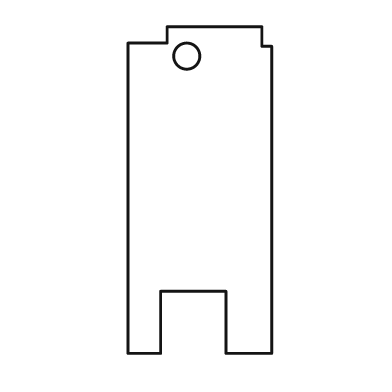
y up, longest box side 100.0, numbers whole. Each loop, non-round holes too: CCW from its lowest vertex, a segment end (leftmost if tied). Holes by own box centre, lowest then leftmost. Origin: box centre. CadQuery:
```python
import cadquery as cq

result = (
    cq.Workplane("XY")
    .moveTo(-22.0, -50.0)
    .lineTo(-12.0, -50.0)
    .lineTo(-12.0, -31.0)
    .lineTo(8.0, -31.0)
    .lineTo(8.0, -50.0)
    .lineTo(22.0, -50.0)
    .lineTo(22.0, 44.0)
    .lineTo(19.0, 44.0)
    .lineTo(19.0, 50.0)
    .lineTo(-10.0, 50.0)
    .lineTo(-10.0, 45.0)
    .lineTo(-22.0, 45.0)
    .close()
    .moveTo(-4.0, 41.0)
    .circle(4.0)
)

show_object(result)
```